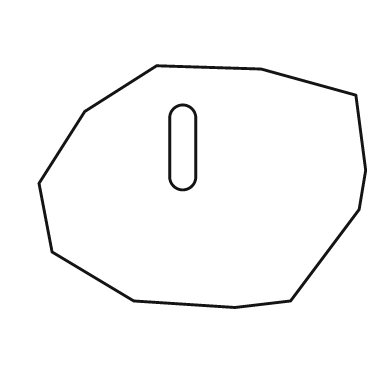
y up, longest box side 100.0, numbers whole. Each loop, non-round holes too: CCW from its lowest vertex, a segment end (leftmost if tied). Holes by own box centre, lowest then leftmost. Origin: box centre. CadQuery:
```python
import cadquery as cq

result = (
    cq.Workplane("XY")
    .moveTo(10.0, -37.0)
    .lineTo(27.0, -35.0)
    .lineTo(48.0, -7.0)
    .lineTo(50.0, 5.0)
    .lineTo(47.0, 28.0)
    .lineTo(18.0, 36.0)
    .lineTo(-14.0, 37.0)
    .lineTo(-36.0, 23.0)
    .lineTo(-50.0, 1.0)
    .lineTo(-46.0, -20.0)
    .lineTo(-21.0, -35.0)
    .close()
    .moveTo(-10.0, 3.0)
    .threePointArc((-6.0, -1.0), (-2.0, 3.0))
    .lineTo(-2.0, 21.0)
    .threePointArc((-6.0, 25.0), (-10.0, 21.0))
    .close()
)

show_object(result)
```